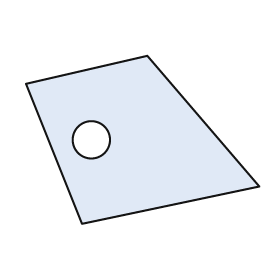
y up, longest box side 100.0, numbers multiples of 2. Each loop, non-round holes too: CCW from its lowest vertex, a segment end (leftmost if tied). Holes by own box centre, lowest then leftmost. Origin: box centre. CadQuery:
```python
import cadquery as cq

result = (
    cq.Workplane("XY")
    .moveTo(-26.0, -36.0)
    .lineTo(50.0, -20.0)
    .lineTo(2.0, 36.0)
    .lineTo(-50.0, 24.0)
    .close()
    .moveTo(-22.0, 0.0)
    .circle(8.0)
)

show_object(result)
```